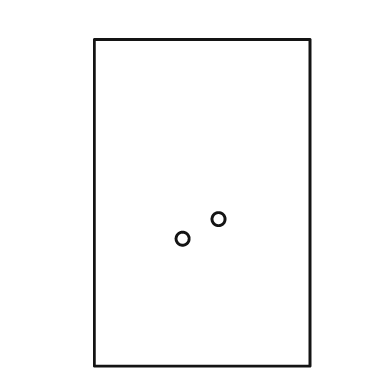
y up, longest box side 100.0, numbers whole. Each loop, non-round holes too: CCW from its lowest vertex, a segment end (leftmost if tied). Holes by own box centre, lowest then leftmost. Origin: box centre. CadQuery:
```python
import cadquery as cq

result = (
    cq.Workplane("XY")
    .moveTo(-33.0, -50.0)
    .lineTo(33.0, -50.0)
    .lineTo(33.0, 50.0)
    .lineTo(-33.0, 50.0)
    .close()
    .moveTo(-6.0, -11.0)
    .circle(2.0)
    .moveTo(5.0, -5.0)
    .circle(2.0)
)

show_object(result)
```